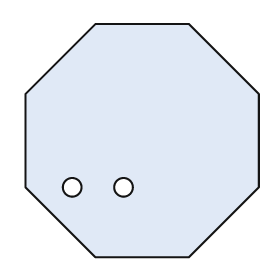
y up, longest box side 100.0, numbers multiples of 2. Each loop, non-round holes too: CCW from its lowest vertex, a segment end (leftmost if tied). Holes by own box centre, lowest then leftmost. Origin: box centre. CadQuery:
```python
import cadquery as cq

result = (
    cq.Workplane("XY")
    .moveTo(-20.0, -50.0)
    .lineTo(20.0, -50.0)
    .lineTo(50.0, -20.0)
    .lineTo(50.0, 20.0)
    .lineTo(20.0, 50.0)
    .lineTo(-20.0, 50.0)
    .lineTo(-50.0, 20.0)
    .lineTo(-50.0, -20.0)
    .close()
    .moveTo(-30.0, -20.0)
    .circle(4.0)
    .moveTo(-8.0, -20.0)
    .circle(4.0)
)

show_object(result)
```